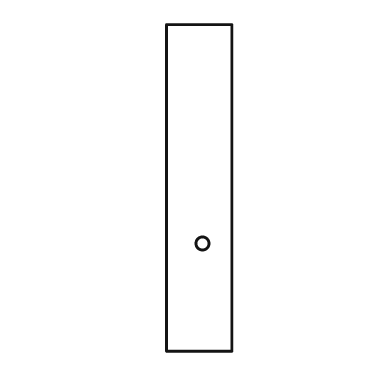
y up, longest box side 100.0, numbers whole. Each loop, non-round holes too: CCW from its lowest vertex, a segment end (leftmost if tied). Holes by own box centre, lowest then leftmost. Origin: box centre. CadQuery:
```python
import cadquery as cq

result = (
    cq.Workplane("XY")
    .moveTo(-10.0, -50.0)
    .lineTo(10.0, -50.0)
    .lineTo(10.0, 50.0)
    .lineTo(-10.0, 50.0)
    .close()
    .moveTo(1.0, -17.0)
    .circle(2.0)
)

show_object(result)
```